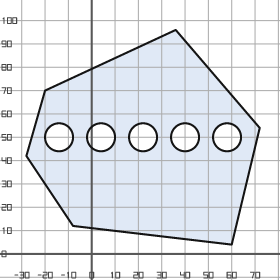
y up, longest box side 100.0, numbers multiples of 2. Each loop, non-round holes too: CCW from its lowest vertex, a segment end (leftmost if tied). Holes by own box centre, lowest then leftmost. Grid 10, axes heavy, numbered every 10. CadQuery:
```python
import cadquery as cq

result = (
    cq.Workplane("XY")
    .moveTo(60.0, 4.0)
    .lineTo(72.0, 54.0)
    .lineTo(36.0, 96.0)
    .lineTo(-20.0, 70.0)
    .lineTo(-28.0, 42.0)
    .lineTo(-8.0, 12.0)
    .close()
    .moveTo(-14.0, 50.0)
    .circle(6.0)
    .moveTo(4.0, 50.0)
    .circle(6.0)
    .moveTo(22.0, 50.0)
    .circle(6.0)
    .moveTo(40.0, 50.0)
    .circle(6.0)
    .moveTo(58.0, 50.0)
    .circle(6.0)
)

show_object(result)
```